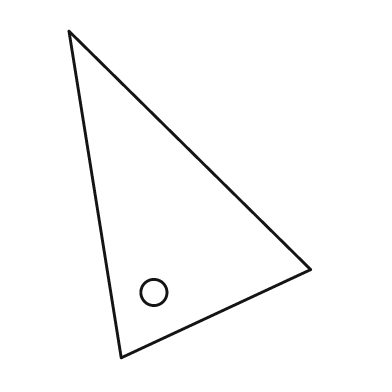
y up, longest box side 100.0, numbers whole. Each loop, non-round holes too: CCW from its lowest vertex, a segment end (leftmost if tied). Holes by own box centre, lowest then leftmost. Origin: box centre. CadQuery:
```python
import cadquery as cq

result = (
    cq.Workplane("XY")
    .moveTo(-21.0, -50.0)
    .lineTo(37.0, -23.0)
    .lineTo(-37.0, 50.0)
    .close()
    .moveTo(-11.0, -30.0)
    .circle(4.0)
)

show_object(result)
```